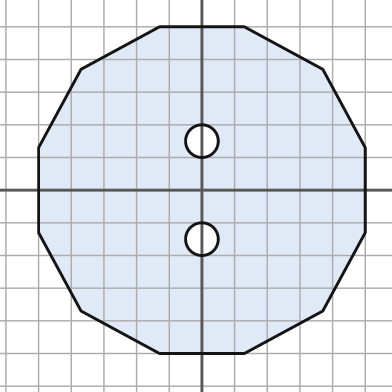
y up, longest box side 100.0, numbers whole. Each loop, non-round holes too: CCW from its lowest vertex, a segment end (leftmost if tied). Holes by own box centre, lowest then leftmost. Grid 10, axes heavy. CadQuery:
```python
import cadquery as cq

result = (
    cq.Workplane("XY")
    .moveTo(-13.0, -50.0)
    .lineTo(13.0, -50.0)
    .lineTo(37.0, -37.0)
    .lineTo(50.0, -13.0)
    .lineTo(50.0, 13.0)
    .lineTo(37.0, 37.0)
    .lineTo(13.0, 50.0)
    .lineTo(-13.0, 50.0)
    .lineTo(-37.0, 37.0)
    .lineTo(-50.0, 13.0)
    .lineTo(-50.0, -13.0)
    .lineTo(-37.0, -37.0)
    .close()
    .moveTo(0.0, -15.0)
    .circle(5.0)
    .moveTo(0.0, 15.0)
    .circle(5.0)
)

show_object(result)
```